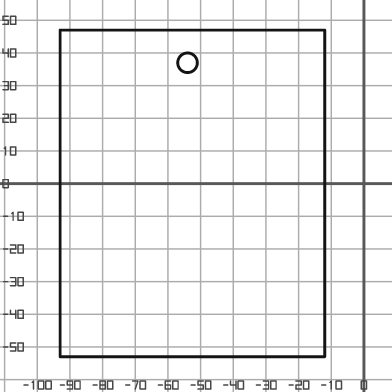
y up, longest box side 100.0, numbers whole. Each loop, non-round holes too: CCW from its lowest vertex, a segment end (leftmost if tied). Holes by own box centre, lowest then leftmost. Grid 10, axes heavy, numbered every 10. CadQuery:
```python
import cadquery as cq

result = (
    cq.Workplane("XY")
    .moveTo(-93.0, -53.0)
    .lineTo(-12.0, -53.0)
    .lineTo(-12.0, 47.0)
    .lineTo(-93.0, 47.0)
    .close()
    .moveTo(-54.0, 37.0)
    .circle(3.0)
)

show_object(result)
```